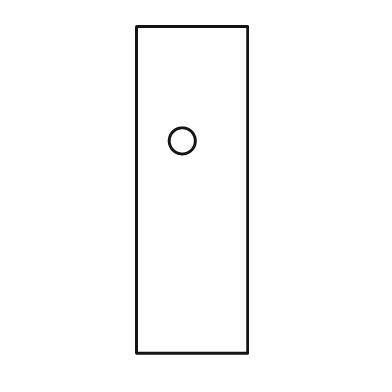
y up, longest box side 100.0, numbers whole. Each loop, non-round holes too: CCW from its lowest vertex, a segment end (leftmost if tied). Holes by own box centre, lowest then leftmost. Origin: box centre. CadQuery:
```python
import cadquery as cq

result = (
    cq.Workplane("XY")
    .moveTo(-17.0, -50.0)
    .lineTo(17.0, -50.0)
    .lineTo(17.0, 50.0)
    .lineTo(-17.0, 50.0)
    .close()
    .moveTo(-3.0, 15.0)
    .circle(4.0)
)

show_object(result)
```